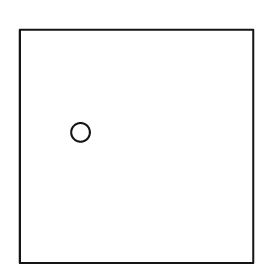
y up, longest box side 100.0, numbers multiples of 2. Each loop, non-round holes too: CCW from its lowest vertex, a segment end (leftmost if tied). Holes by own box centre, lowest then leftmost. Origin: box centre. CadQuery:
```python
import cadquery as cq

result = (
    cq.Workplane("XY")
    .moveTo(-50.0, -50.0)
    .lineTo(50.0, -50.0)
    .lineTo(50.0, 50.0)
    .lineTo(-50.0, 50.0)
    .close()
    .moveTo(-24.0, 6.0)
    .circle(4.0)
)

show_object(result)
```